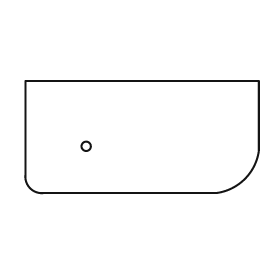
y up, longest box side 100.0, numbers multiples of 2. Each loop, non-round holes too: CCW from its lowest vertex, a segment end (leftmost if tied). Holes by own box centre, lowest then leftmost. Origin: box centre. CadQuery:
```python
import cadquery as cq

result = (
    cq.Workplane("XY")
    .moveTo(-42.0, -24.0)
    .lineTo(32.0, -24.0)
    .threePointArc((44.0, -18.0), (50.0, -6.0))
    .lineTo(50.0, 24.0)
    .lineTo(-50.0, 24.0)
    .lineTo(-50.0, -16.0)
    .threePointArc((-48.0, -22.0), (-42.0, -24.0))
    .close()
    .moveTo(-24.0, -4.0)
    .circle(2.0)
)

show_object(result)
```